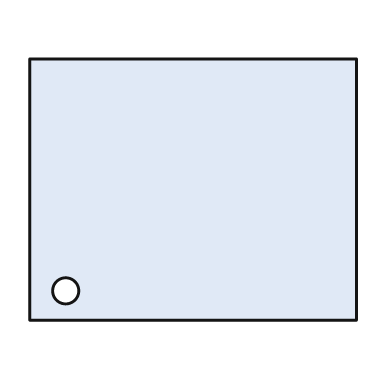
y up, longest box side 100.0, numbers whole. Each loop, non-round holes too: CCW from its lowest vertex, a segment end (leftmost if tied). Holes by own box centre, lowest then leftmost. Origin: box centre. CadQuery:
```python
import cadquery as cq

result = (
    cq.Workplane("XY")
    .moveTo(-50.0, -40.0)
    .lineTo(50.0, -40.0)
    .lineTo(50.0, 40.0)
    .lineTo(-50.0, 40.0)
    .close()
    .moveTo(-39.0, -31.0)
    .circle(4.0)
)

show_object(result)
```